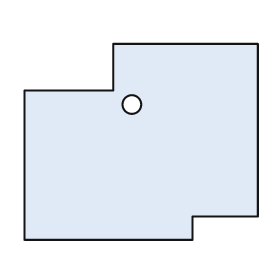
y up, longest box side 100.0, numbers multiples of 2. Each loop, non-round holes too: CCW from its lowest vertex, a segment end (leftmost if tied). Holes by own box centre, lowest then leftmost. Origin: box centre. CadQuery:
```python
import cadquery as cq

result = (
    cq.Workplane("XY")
    .moveTo(-50.0, -42.0)
    .lineTo(22.0, -42.0)
    .lineTo(22.0, -32.0)
    .lineTo(50.0, -32.0)
    .lineTo(50.0, 42.0)
    .lineTo(-12.0, 42.0)
    .lineTo(-12.0, 22.0)
    .lineTo(-50.0, 22.0)
    .close()
    .moveTo(-4.0, 16.0)
    .circle(4.0)
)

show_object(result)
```